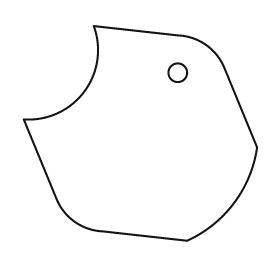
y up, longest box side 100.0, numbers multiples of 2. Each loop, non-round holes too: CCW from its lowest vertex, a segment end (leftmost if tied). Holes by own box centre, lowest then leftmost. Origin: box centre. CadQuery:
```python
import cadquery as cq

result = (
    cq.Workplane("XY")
    .moveTo(20.0, -46.0)
    .threePointArc((40.0, -30.0), (50.0, -6.0))
    .lineTo(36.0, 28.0)
    .threePointArc((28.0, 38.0), (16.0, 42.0))
    .lineTo(-20.0, 46.0)
    .threePointArc((-24.0, 18.0), (-50.0, 6.0))
    .lineTo(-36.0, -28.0)
    .threePointArc((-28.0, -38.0), (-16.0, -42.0))
    .close()
    .moveTo(16.0, 26.0)
    .circle(4.0)
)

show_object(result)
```